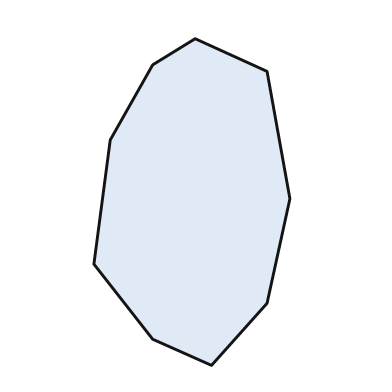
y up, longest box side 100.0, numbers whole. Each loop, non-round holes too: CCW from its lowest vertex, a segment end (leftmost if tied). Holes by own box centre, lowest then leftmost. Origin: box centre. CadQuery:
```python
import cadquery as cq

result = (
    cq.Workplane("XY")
    .moveTo(6.0, -50.0)
    .lineTo(23.0, -31.0)
    .lineTo(30.0, 1.0)
    .lineTo(23.0, 40.0)
    .lineTo(1.0, 50.0)
    .lineTo(-12.0, 42.0)
    .lineTo(-25.0, 19.0)
    .lineTo(-30.0, -19.0)
    .lineTo(-12.0, -42.0)
    .close()
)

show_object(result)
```